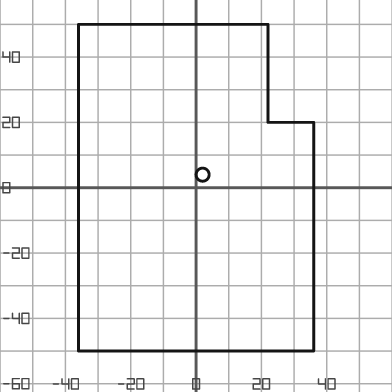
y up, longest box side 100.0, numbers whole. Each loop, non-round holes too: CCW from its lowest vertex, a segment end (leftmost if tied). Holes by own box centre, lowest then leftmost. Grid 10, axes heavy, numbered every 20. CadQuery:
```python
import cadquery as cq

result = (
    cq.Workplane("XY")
    .moveTo(-36.0, -50.0)
    .lineTo(36.0, -50.0)
    .lineTo(36.0, 20.0)
    .lineTo(22.0, 20.0)
    .lineTo(22.0, 50.0)
    .lineTo(-36.0, 50.0)
    .close()
    .moveTo(2.0, 4.0)
    .circle(2.0)
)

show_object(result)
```